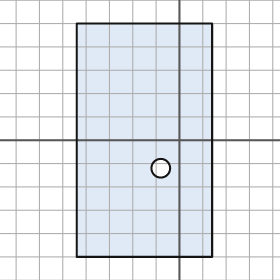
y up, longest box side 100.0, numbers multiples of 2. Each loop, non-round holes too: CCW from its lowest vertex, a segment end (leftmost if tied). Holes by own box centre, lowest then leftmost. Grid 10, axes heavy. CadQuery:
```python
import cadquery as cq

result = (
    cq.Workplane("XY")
    .moveTo(-44.0, -50.0)
    .lineTo(14.0, -50.0)
    .lineTo(14.0, 50.0)
    .lineTo(-44.0, 50.0)
    .close()
    .moveTo(-8.0, -12.0)
    .circle(4.0)
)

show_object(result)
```